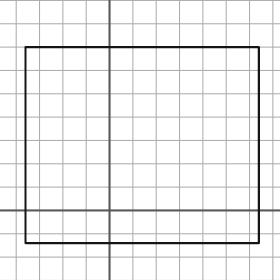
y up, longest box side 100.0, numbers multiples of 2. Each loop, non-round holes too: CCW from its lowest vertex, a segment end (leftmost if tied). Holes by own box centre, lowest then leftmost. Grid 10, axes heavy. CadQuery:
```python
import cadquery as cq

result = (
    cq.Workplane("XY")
    .moveTo(-36.0, -14.0)
    .lineTo(64.0, -14.0)
    .lineTo(64.0, 70.0)
    .lineTo(-36.0, 70.0)
    .close()
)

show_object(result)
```